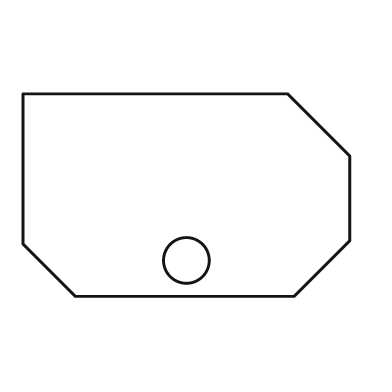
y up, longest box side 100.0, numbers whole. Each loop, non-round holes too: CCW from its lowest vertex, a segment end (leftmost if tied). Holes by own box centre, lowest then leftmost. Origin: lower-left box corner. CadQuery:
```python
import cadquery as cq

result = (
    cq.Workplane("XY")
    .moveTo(16.0, 0.0)
    .lineTo(83.0, 0.0)
    .lineTo(100.0, 17.0)
    .lineTo(100.0, 43.0)
    .lineTo(81.0, 62.0)
    .lineTo(0.0, 62.0)
    .lineTo(0.0, 16.0)
    .close()
    .moveTo(50.0, 11.0)
    .circle(7.0)
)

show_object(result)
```